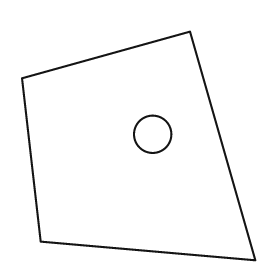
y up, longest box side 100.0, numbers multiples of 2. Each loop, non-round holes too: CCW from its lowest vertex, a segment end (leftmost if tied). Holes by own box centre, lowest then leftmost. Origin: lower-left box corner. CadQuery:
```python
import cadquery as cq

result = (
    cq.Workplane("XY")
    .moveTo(100.0, 0.0)
    .lineTo(72.0, 98.0)
    .lineTo(0.0, 78.0)
    .lineTo(8.0, 8.0)
    .close()
    .moveTo(56.0, 54.0)
    .circle(8.0)
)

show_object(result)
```